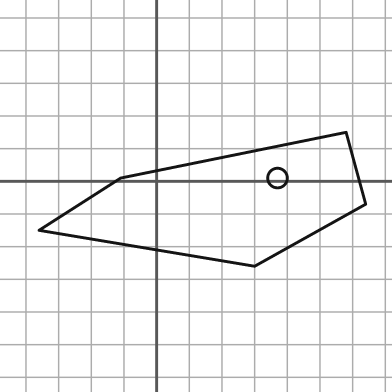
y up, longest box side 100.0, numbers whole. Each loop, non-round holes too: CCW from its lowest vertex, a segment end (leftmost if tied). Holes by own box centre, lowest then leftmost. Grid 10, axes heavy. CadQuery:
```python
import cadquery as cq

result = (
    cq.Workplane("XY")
    .moveTo(30.0, -26.0)
    .lineTo(64.0, -7.0)
    .lineTo(58.0, 15.0)
    .lineTo(-11.0, 1.0)
    .lineTo(-36.0, -15.0)
    .close()
    .moveTo(37.0, 1.0)
    .circle(3.0)
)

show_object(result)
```